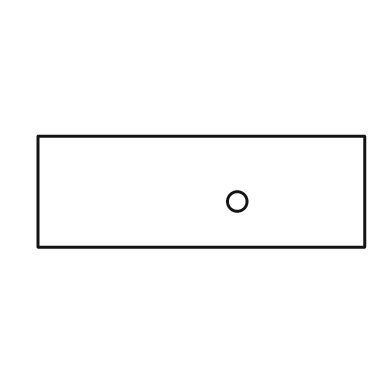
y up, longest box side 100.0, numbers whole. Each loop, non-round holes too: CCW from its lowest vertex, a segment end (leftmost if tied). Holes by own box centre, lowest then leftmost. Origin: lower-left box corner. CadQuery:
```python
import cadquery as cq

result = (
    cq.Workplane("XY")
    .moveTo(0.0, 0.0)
    .lineTo(100.0, 0.0)
    .lineTo(100.0, 34.0)
    .lineTo(0.0, 34.0)
    .close()
    .moveTo(61.0, 14.0)
    .circle(3.0)
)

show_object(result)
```